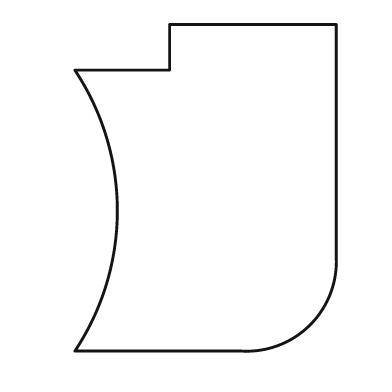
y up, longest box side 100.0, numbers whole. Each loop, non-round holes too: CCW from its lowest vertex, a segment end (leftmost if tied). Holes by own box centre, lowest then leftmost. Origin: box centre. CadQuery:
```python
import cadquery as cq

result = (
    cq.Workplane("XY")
    .moveTo(-40.0, -50.0)
    .lineTo(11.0, -50.0)
    .threePointArc((32.0, -42.0), (40.0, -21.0))
    .lineTo(40.0, 50.0)
    .lineTo(-11.0, 50.0)
    .lineTo(-11.0, 36.0)
    .lineTo(-40.0, 36.0)
    .threePointArc((-27.0, -7.0), (-40.0, -50.0))
    .close()
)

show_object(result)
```